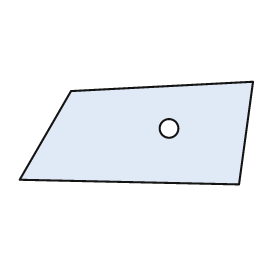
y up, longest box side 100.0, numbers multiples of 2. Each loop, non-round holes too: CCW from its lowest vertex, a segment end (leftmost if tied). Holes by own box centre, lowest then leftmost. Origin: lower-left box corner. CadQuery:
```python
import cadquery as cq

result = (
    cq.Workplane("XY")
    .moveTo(94.0, 0.0)
    .lineTo(100.0, 44.0)
    .lineTo(22.0, 40.0)
    .lineTo(0.0, 2.0)
    .close()
    .moveTo(64.0, 24.0)
    .circle(4.0)
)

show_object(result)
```